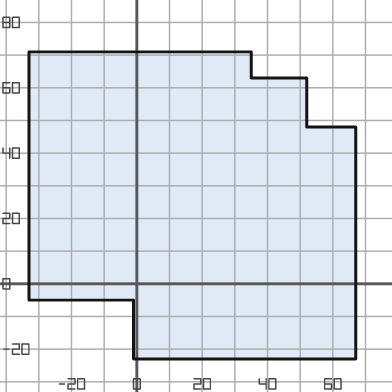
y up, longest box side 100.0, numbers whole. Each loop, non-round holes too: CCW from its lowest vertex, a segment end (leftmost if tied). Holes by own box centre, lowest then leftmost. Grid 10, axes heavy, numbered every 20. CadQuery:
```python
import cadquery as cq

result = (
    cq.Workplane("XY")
    .moveTo(-1.0, -23.0)
    .lineTo(67.0, -23.0)
    .lineTo(67.0, 48.0)
    .lineTo(52.0, 48.0)
    .lineTo(52.0, 63.0)
    .lineTo(35.0, 63.0)
    .lineTo(35.0, 71.0)
    .lineTo(-33.0, 71.0)
    .lineTo(-33.0, -5.0)
    .lineTo(-1.0, -5.0)
    .close()
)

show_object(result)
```